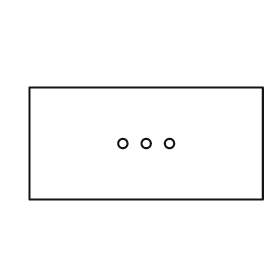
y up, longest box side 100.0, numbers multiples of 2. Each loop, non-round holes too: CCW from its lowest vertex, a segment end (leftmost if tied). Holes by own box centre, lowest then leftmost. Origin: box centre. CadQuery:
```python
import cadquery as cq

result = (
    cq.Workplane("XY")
    .moveTo(-50.0, -24.0)
    .lineTo(50.0, -24.0)
    .lineTo(50.0, 24.0)
    .lineTo(-50.0, 24.0)
    .close()
    .moveTo(-10.0, 0.0)
    .circle(2.0)
    .moveTo(0.0, 0.0)
    .circle(2.0)
    .moveTo(10.0, 0.0)
    .circle(2.0)
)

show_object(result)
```